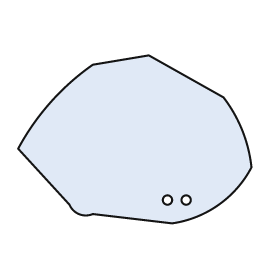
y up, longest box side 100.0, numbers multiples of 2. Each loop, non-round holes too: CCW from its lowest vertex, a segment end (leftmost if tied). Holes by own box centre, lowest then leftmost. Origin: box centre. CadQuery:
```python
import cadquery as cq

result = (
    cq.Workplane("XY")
    .moveTo(16.0, -36.0)
    .threePointArc((36.0, -28.0), (50.0, -12.0))
    .threePointArc((46.0, 4.0), (38.0, 18.0))
    .lineTo(6.0, 36.0)
    .lineTo(-18.0, 32.0)
    .threePointArc((-36.0, 16.0), (-50.0, -4.0))
    .lineTo(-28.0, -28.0)
    .threePointArc((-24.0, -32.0), (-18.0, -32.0))
    .close()
    .moveTo(14.0, -26.0)
    .circle(2.0)
    .moveTo(22.0, -26.0)
    .circle(2.0)
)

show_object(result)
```